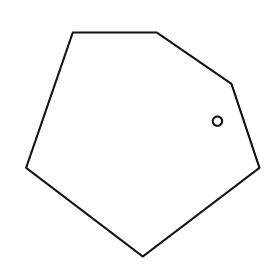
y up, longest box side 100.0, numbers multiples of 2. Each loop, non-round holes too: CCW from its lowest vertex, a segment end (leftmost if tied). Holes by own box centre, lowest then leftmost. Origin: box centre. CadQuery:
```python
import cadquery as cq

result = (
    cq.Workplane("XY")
    .moveTo(0.0, -48.0)
    .lineTo(50.0, -10.0)
    .lineTo(38.0, 26.0)
    .lineTo(6.0, 48.0)
    .lineTo(-30.0, 48.0)
    .lineTo(-50.0, -10.0)
    .close()
    .moveTo(32.0, 10.0)
    .circle(2.0)
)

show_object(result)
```